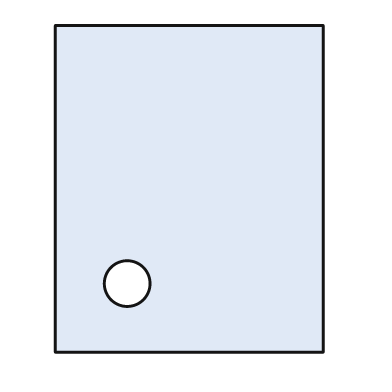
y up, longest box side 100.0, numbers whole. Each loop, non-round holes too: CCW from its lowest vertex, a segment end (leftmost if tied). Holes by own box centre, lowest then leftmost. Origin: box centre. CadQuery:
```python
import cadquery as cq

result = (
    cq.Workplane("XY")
    .moveTo(-41.0, -50.0)
    .lineTo(41.0, -50.0)
    .lineTo(41.0, 50.0)
    .lineTo(-41.0, 50.0)
    .close()
    .moveTo(-19.0, -29.0)
    .circle(7.0)
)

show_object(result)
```